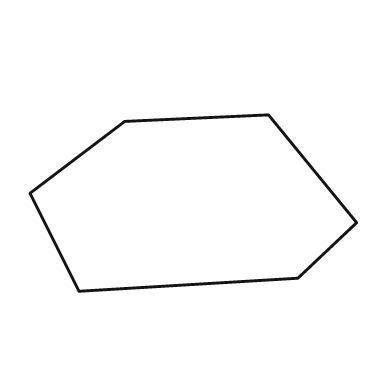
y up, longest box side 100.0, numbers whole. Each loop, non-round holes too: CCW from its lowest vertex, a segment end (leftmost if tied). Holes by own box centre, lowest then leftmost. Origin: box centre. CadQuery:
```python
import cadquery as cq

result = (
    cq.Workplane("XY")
    .moveTo(-35.0, -27.0)
    .lineTo(32.0, -23.0)
    .lineTo(50.0, -6.0)
    .lineTo(23.0, 27.0)
    .lineTo(-21.0, 25.0)
    .lineTo(-50.0, 3.0)
    .close()
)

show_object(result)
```